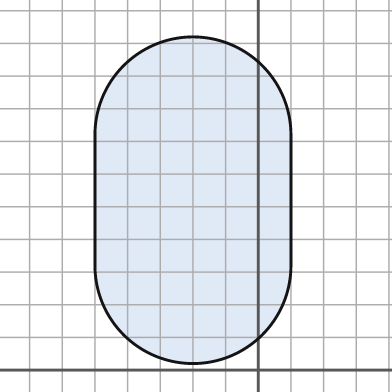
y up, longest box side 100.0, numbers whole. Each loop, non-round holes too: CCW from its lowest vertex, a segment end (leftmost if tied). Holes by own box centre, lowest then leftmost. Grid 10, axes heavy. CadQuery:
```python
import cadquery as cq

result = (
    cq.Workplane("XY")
    .moveTo(-50.0, 32.0)
    .threePointArc((-20.0, 2.0), (10.0, 32.0))
    .lineTo(10.0, 72.0)
    .threePointArc((-20.0, 102.0), (-50.0, 72.0))
    .close()
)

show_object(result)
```